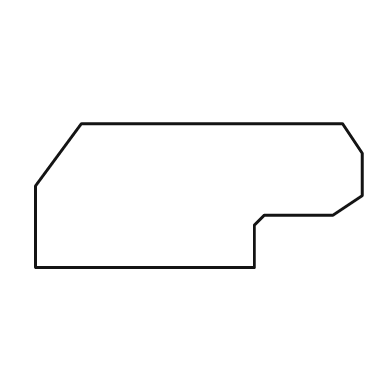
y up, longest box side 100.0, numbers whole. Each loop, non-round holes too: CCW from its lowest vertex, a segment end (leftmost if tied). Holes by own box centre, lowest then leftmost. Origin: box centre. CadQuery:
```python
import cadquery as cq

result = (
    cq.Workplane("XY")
    .moveTo(-50.0, -22.0)
    .lineTo(17.0, -22.0)
    .lineTo(17.0, -9.0)
    .lineTo(20.0, -6.0)
    .lineTo(41.0, -6.0)
    .lineTo(50.0, 0.0)
    .lineTo(50.0, 13.0)
    .lineTo(44.0, 22.0)
    .lineTo(-36.0, 22.0)
    .lineTo(-50.0, 3.0)
    .close()
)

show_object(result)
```